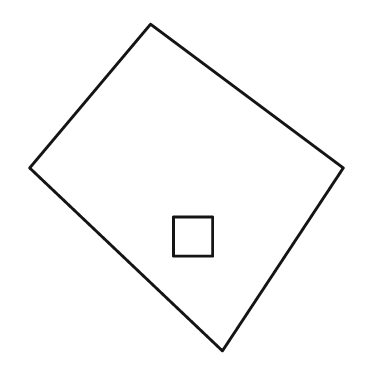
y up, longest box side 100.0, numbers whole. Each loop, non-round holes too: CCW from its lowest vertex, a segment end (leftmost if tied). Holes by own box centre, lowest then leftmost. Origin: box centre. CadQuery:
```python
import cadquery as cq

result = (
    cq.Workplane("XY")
    .moveTo(11.0, -50.0)
    .lineTo(48.0, 6.0)
    .lineTo(-11.0, 50.0)
    .lineTo(-48.0, 6.0)
    .close()
    .moveTo(-4.0, -21.0)
    .lineTo(8.0, -21.0)
    .lineTo(8.0, -9.0)
    .lineTo(-4.0, -9.0)
    .close()
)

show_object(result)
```